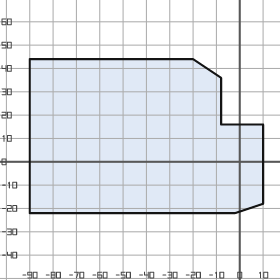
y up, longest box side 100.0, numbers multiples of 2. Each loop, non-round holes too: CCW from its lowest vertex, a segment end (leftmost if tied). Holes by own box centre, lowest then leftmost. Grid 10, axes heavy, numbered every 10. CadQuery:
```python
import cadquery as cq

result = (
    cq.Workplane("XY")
    .moveTo(-90.0, -22.0)
    .lineTo(-2.0, -22.0)
    .lineTo(10.0, -18.0)
    .lineTo(10.0, 16.0)
    .lineTo(-8.0, 16.0)
    .lineTo(-8.0, 36.0)
    .lineTo(-20.0, 44.0)
    .lineTo(-90.0, 44.0)
    .close()
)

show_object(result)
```